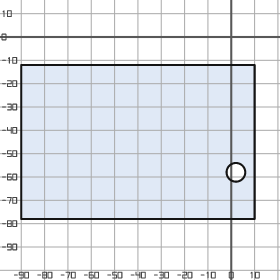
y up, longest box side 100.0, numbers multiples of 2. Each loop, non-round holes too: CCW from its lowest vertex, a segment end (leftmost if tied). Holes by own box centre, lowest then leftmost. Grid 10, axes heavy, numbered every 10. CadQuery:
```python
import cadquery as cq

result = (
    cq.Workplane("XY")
    .moveTo(-90.0, -78.0)
    .lineTo(10.0, -78.0)
    .lineTo(10.0, -12.0)
    .lineTo(-90.0, -12.0)
    .close()
    .moveTo(2.0, -58.0)
    .circle(4.0)
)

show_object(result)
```